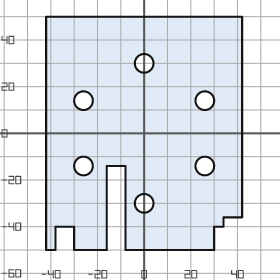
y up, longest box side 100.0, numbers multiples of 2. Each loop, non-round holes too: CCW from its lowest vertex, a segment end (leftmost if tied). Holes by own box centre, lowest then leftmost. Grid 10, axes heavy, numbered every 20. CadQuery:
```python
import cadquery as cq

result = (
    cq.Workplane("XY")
    .moveTo(-42.0, -50.0)
    .lineTo(-38.0, -50.0)
    .lineTo(-38.0, -40.0)
    .lineTo(-30.0, -40.0)
    .lineTo(-30.0, -50.0)
    .lineTo(-16.0, -50.0)
    .lineTo(-16.0, -14.0)
    .lineTo(-8.0, -14.0)
    .lineTo(-8.0, -50.0)
    .lineTo(30.0, -50.0)
    .lineTo(30.0, -40.0)
    .lineTo(34.0, -40.0)
    .lineTo(34.0, -36.0)
    .lineTo(42.0, -36.0)
    .lineTo(42.0, 50.0)
    .lineTo(-42.0, 50.0)
    .close()
    .moveTo(0.0, -30.0)
    .circle(4.0)
    .moveTo(-26.0, -14.0)
    .circle(4.0)
    .moveTo(26.0, -14.0)
    .circle(4.0)
    .moveTo(-26.0, 14.0)
    .circle(4.0)
    .moveTo(26.0, 14.0)
    .circle(4.0)
    .moveTo(0.0, 30.0)
    .circle(4.0)
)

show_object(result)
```